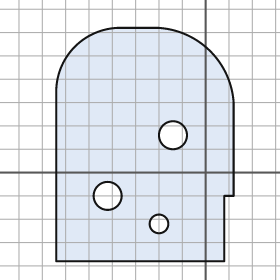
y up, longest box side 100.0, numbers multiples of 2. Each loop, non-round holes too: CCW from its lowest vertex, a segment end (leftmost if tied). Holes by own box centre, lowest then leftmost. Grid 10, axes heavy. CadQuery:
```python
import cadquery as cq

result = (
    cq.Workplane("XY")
    .moveTo(-64.0, -38.0)
    .lineTo(8.0, -38.0)
    .lineTo(8.0, -10.0)
    .lineTo(12.0, -10.0)
    .lineTo(12.0, 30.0)
    .threePointArc((2.0, 52.0), (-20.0, 62.0))
    .lineTo(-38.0, 62.0)
    .threePointArc((-56.0, 54.0), (-64.0, 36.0))
    .close()
    .moveTo(-20.0, -22.0)
    .circle(4.0)
    .moveTo(-42.0, -10.0)
    .circle(6.0)
    .moveTo(-14.0, 16.0)
    .circle(6.0)
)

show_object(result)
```